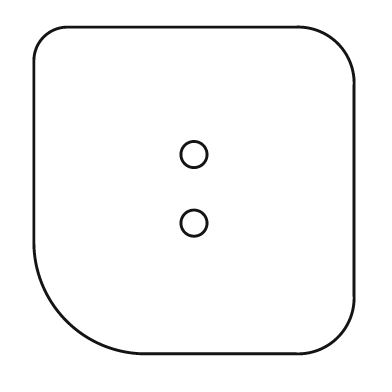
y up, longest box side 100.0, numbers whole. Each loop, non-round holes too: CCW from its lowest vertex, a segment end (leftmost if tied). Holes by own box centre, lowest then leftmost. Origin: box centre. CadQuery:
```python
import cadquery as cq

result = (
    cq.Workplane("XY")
    .moveTo(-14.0, -50.0)
    .lineTo(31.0, -50.0)
    .threePointArc((44.0, -45.0), (49.0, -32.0))
    .lineTo(49.0, 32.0)
    .threePointArc((44.0, 45.0), (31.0, 50.0))
    .lineTo(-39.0, 50.0)
    .threePointArc((-46.0, 47.0), (-49.0, 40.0))
    .lineTo(-49.0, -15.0)
    .threePointArc((-39.0, -40.0), (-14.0, -50.0))
    .close()
    .moveTo(0.0, -10.0)
    .circle(4.0)
    .moveTo(0.0, 11.0)
    .circle(4.0)
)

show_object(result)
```